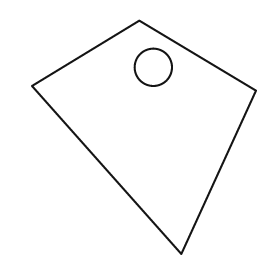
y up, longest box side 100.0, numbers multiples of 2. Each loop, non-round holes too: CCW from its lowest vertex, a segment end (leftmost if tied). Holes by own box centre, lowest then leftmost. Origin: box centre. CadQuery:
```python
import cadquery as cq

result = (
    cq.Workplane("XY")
    .moveTo(16.0, -50.0)
    .lineTo(48.0, 20.0)
    .lineTo(-2.0, 50.0)
    .lineTo(-48.0, 22.0)
    .close()
    .moveTo(4.0, 30.0)
    .circle(8.0)
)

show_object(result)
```